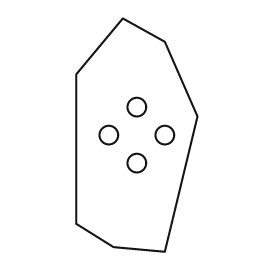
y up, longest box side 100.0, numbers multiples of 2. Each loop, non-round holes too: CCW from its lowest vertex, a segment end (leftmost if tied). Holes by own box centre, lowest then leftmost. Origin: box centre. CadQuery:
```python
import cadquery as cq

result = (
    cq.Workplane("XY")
    .moveTo(12.0, -50.0)
    .lineTo(26.0, 8.0)
    .lineTo(12.0, 40.0)
    .lineTo(-6.0, 50.0)
    .lineTo(-26.0, 26.0)
    .lineTo(-26.0, -38.0)
    .lineTo(-10.0, -48.0)
    .close()
    .moveTo(0.0, -12.0)
    .circle(4.0)
    .moveTo(-12.0, 0.0)
    .circle(4.0)
    .moveTo(12.0, 0.0)
    .circle(4.0)
    .moveTo(0.0, 12.0)
    .circle(4.0)
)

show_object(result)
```